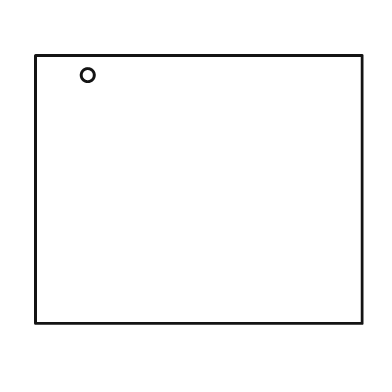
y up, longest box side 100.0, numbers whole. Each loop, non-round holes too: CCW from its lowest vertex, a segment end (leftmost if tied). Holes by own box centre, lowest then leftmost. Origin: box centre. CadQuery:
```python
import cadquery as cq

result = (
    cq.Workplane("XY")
    .moveTo(-50.0, -41.0)
    .lineTo(50.0, -41.0)
    .lineTo(50.0, 41.0)
    .lineTo(-50.0, 41.0)
    .close()
    .moveTo(-34.0, 35.0)
    .circle(2.0)
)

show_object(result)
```